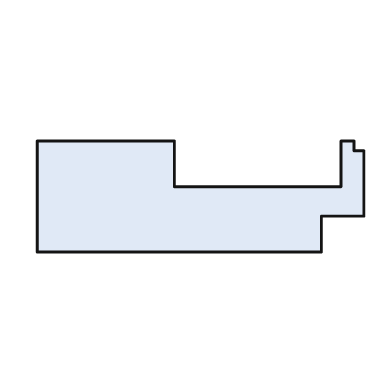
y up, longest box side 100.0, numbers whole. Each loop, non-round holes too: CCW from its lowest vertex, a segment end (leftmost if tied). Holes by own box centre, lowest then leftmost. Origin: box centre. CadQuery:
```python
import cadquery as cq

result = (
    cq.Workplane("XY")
    .moveTo(-50.0, -17.0)
    .lineTo(37.0, -17.0)
    .lineTo(37.0, -6.0)
    .lineTo(50.0, -6.0)
    .lineTo(50.0, 14.0)
    .lineTo(47.0, 14.0)
    .lineTo(47.0, 17.0)
    .lineTo(43.0, 17.0)
    .lineTo(43.0, 3.0)
    .lineTo(-8.0, 3.0)
    .lineTo(-8.0, 17.0)
    .lineTo(-50.0, 17.0)
    .close()
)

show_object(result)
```